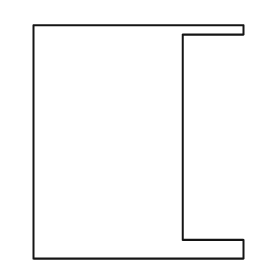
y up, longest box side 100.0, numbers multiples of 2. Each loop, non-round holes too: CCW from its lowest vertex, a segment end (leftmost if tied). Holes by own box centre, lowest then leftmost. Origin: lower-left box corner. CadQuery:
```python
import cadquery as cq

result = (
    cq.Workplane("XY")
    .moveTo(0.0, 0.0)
    .lineTo(90.0, 0.0)
    .lineTo(90.0, 8.0)
    .lineTo(64.0, 8.0)
    .lineTo(64.0, 96.0)
    .lineTo(90.0, 96.0)
    .lineTo(90.0, 100.0)
    .lineTo(0.0, 100.0)
    .close()
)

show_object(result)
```